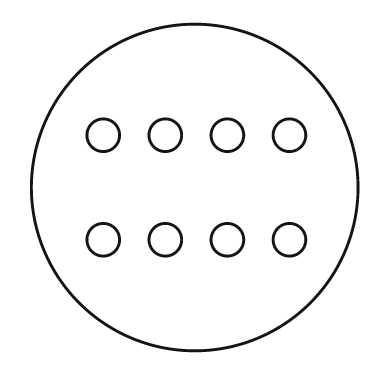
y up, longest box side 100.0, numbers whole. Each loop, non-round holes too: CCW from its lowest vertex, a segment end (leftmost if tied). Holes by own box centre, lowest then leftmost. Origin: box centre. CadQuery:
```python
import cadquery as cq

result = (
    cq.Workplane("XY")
    .moveTo(0.0, 0.0)
    .circle(50.0)
    .moveTo(-28.0, -16.0)
    .circle(5.0)
    .moveTo(-9.0, -16.0)
    .circle(5.0)
    .moveTo(10.0, -16.0)
    .circle(5.0)
    .moveTo(29.0, -16.0)
    .circle(5.0)
    .moveTo(-28.0, 16.0)
    .circle(5.0)
    .moveTo(-9.0, 16.0)
    .circle(5.0)
    .moveTo(10.0, 16.0)
    .circle(5.0)
    .moveTo(29.0, 16.0)
    .circle(5.0)
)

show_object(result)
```